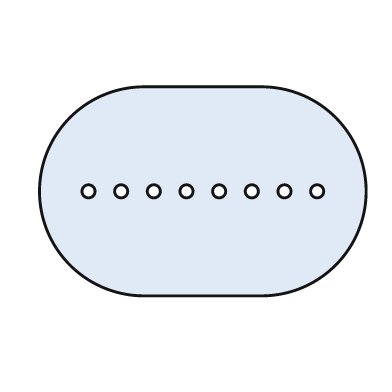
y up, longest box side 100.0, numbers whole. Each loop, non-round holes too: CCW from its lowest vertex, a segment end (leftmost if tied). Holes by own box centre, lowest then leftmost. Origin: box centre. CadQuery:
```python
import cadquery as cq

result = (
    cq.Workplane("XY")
    .moveTo(-18.0, -32.0)
    .lineTo(18.0, -32.0)
    .threePointArc((50.0, 0.0), (18.0, 32.0))
    .lineTo(-18.0, 32.0)
    .threePointArc((-50.0, 0.0), (-18.0, -32.0))
    .close()
    .moveTo(-35.0, 0.0)
    .circle(2.0)
    .moveTo(-25.0, 0.0)
    .circle(2.0)
    .moveTo(-15.0, 0.0)
    .circle(2.0)
    .moveTo(-5.0, 0.0)
    .circle(2.0)
    .moveTo(5.0, 0.0)
    .circle(2.0)
    .moveTo(15.0, 0.0)
    .circle(2.0)
    .moveTo(25.0, 0.0)
    .circle(2.0)
    .moveTo(35.0, 0.0)
    .circle(2.0)
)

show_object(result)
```